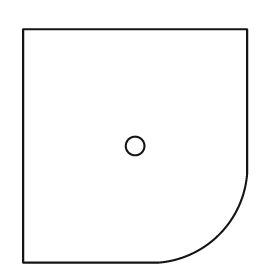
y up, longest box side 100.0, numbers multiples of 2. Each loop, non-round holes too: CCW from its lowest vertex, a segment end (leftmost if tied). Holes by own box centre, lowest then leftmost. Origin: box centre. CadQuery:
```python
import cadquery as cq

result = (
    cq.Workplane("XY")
    .moveTo(-48.0, -50.0)
    .lineTo(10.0, -50.0)
    .threePointArc((36.0, -38.0), (48.0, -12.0))
    .lineTo(48.0, 50.0)
    .lineTo(-48.0, 50.0)
    .close()
    .moveTo(0.0, 0.0)
    .circle(4.0)
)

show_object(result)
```